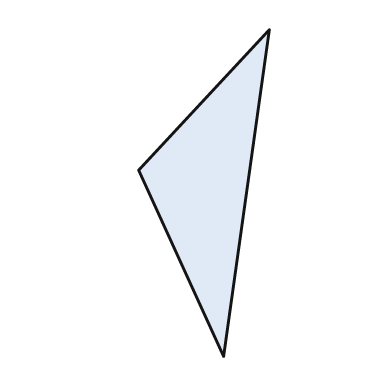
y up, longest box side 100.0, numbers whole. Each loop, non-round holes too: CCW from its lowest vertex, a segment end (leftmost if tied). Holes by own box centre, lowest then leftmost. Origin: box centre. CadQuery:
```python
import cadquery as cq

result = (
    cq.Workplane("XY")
    .moveTo(6.0, -50.0)
    .lineTo(20.0, 50.0)
    .lineTo(-20.0, 7.0)
    .close()
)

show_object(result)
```